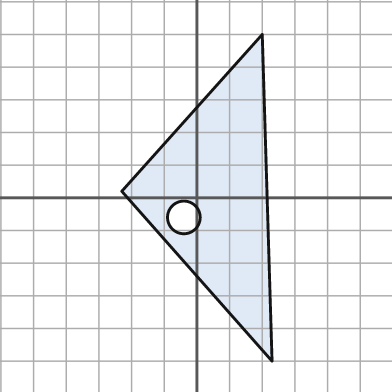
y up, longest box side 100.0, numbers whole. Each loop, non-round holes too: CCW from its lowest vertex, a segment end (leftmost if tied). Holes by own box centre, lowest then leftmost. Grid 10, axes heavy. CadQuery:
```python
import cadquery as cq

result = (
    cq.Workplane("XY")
    .moveTo(23.0, -50.0)
    .lineTo(20.0, 50.0)
    .lineTo(-23.0, 2.0)
    .close()
    .moveTo(-4.0, -6.0)
    .circle(5.0)
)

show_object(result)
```